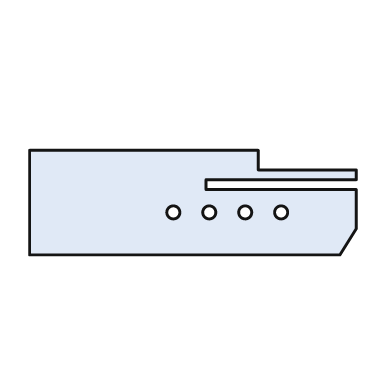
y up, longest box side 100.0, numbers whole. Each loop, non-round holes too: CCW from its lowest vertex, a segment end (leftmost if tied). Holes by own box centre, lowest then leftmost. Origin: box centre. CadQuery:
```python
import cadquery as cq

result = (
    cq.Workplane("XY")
    .moveTo(-50.0, -16.0)
    .lineTo(45.0, -16.0)
    .lineTo(50.0, -8.0)
    .lineTo(50.0, 4.0)
    .lineTo(4.0, 4.0)
    .lineTo(4.0, 7.0)
    .lineTo(50.0, 7.0)
    .lineTo(50.0, 10.0)
    .lineTo(20.0, 10.0)
    .lineTo(20.0, 16.0)
    .lineTo(-50.0, 16.0)
    .close()
    .moveTo(-6.0, -3.0)
    .circle(2.0)
    .moveTo(5.0, -3.0)
    .circle(2.0)
    .moveTo(16.0, -3.0)
    .circle(2.0)
    .moveTo(27.0, -3.0)
    .circle(2.0)
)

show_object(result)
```